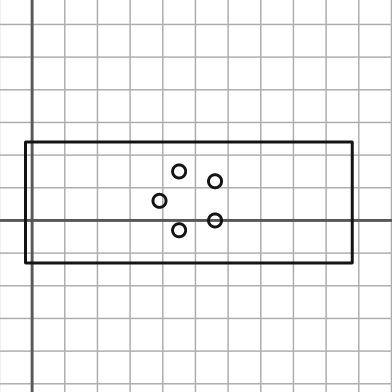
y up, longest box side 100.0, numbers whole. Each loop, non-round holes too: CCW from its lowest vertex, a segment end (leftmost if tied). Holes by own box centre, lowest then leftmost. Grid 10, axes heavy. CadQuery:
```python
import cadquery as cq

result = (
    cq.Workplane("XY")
    .moveTo(-2.0, -13.0)
    .lineTo(98.0, -13.0)
    .lineTo(98.0, 24.0)
    .lineTo(-2.0, 24.0)
    .close()
    .moveTo(45.0, -3.0)
    .circle(2.0)
    .moveTo(56.0, 0.0)
    .circle(2.0)
    .moveTo(39.0, 6.0)
    .circle(2.0)
    .moveTo(56.0, 12.0)
    .circle(2.0)
    .moveTo(45.0, 15.0)
    .circle(2.0)
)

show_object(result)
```